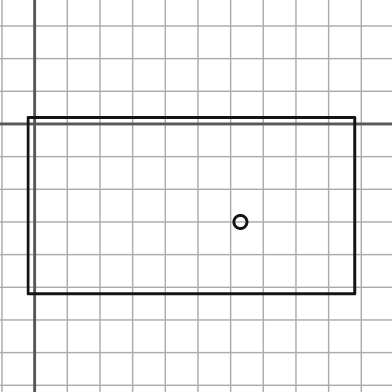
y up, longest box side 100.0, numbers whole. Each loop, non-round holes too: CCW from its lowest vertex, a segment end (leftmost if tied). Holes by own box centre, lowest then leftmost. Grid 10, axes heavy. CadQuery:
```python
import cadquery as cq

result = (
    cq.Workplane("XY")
    .moveTo(-2.0, -52.0)
    .lineTo(98.0, -52.0)
    .lineTo(98.0, 2.0)
    .lineTo(-2.0, 2.0)
    .close()
    .moveTo(63.0, -30.0)
    .circle(2.0)
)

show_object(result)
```